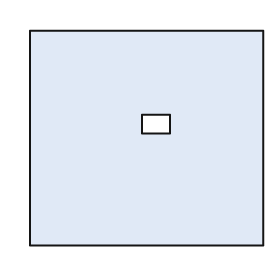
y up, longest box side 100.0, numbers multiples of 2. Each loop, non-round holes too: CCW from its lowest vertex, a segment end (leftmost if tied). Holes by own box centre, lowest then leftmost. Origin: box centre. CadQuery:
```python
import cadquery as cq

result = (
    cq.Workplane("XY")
    .moveTo(-50.0, -46.0)
    .lineTo(50.0, -46.0)
    .lineTo(50.0, 46.0)
    .lineTo(-50.0, 46.0)
    .close()
    .moveTo(-2.0, 2.0)
    .lineTo(10.0, 2.0)
    .lineTo(10.0, 10.0)
    .lineTo(-2.0, 10.0)
    .close()
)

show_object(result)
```